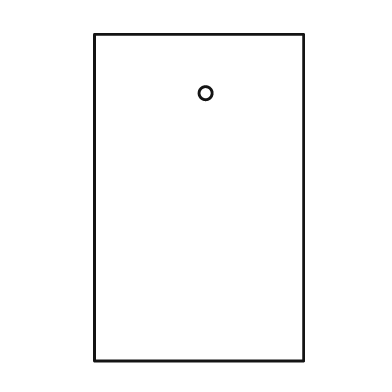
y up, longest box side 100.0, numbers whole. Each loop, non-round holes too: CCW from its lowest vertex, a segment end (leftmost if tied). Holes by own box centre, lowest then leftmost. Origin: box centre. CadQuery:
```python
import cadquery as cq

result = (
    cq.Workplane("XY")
    .moveTo(-32.0, -50.0)
    .lineTo(32.0, -50.0)
    .lineTo(32.0, 50.0)
    .lineTo(-32.0, 50.0)
    .close()
    .moveTo(2.0, 32.0)
    .circle(2.0)
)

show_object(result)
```